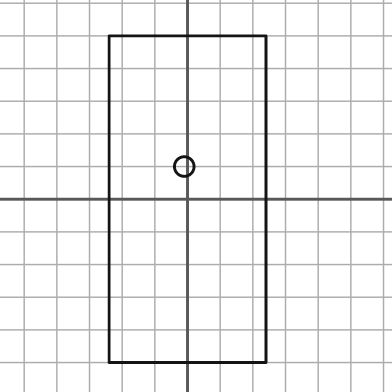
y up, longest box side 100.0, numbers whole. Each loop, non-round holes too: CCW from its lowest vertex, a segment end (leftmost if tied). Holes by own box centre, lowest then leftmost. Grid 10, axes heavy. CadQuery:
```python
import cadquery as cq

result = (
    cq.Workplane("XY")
    .moveTo(-24.0, -50.0)
    .lineTo(24.0, -50.0)
    .lineTo(24.0, 50.0)
    .lineTo(-24.0, 50.0)
    .close()
    .moveTo(-1.0, 10.0)
    .circle(3.0)
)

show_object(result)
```